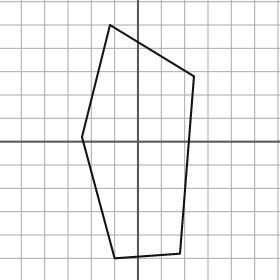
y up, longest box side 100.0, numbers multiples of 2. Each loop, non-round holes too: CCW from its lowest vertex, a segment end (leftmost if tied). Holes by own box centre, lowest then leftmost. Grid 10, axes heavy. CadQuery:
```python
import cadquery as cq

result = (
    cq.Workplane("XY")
    .moveTo(-10.0, -50.0)
    .lineTo(18.0, -48.0)
    .lineTo(24.0, 28.0)
    .lineTo(-12.0, 50.0)
    .lineTo(-24.0, 2.0)
    .close()
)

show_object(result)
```